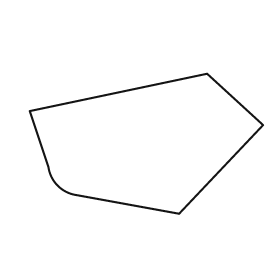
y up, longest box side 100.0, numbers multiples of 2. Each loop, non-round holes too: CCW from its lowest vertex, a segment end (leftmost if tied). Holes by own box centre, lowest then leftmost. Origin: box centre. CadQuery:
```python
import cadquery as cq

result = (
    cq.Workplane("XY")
    .moveTo(14.0, -30.0)
    .lineTo(50.0, 8.0)
    .lineTo(26.0, 30.0)
    .lineTo(-50.0, 14.0)
    .lineTo(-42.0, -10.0)
    .threePointArc((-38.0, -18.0), (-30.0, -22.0))
    .close()
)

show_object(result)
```